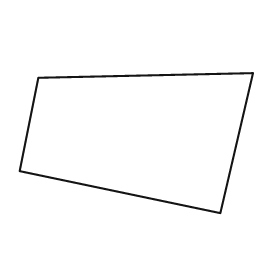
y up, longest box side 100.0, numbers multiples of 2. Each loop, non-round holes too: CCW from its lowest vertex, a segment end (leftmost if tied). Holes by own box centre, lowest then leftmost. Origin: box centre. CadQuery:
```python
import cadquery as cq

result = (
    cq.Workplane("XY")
    .moveTo(36.0, -30.0)
    .lineTo(50.0, 30.0)
    .lineTo(-42.0, 28.0)
    .lineTo(-50.0, -12.0)
    .close()
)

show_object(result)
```